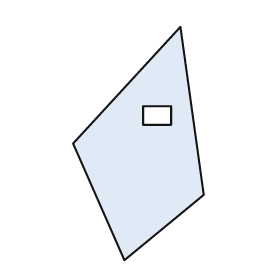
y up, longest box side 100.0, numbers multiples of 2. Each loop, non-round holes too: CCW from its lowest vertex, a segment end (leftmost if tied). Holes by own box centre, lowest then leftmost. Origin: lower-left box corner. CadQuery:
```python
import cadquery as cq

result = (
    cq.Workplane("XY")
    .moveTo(22.0, 0.0)
    .lineTo(56.0, 28.0)
    .lineTo(46.0, 100.0)
    .lineTo(0.0, 50.0)
    .close()
    .moveTo(30.0, 58.0)
    .lineTo(42.0, 58.0)
    .lineTo(42.0, 66.0)
    .lineTo(30.0, 66.0)
    .close()
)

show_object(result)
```